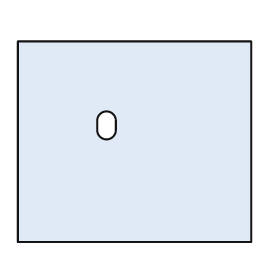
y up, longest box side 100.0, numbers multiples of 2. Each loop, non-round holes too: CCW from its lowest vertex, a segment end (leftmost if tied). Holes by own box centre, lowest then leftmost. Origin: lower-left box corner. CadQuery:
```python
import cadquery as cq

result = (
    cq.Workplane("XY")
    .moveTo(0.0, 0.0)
    .lineTo(100.0, 0.0)
    .lineTo(100.0, 86.0)
    .lineTo(0.0, 86.0)
    .close()
    .moveTo(34.0, 48.0)
    .threePointArc((38.0, 44.0), (42.0, 48.0))
    .lineTo(42.0, 52.0)
    .threePointArc((38.0, 56.0), (34.0, 52.0))
    .close()
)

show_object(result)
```